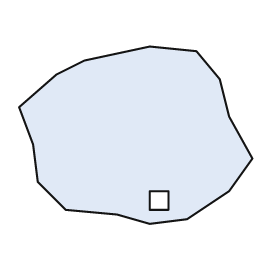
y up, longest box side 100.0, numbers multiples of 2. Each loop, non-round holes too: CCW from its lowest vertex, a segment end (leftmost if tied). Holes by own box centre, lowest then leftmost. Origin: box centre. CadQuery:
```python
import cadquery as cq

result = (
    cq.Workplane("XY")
    .moveTo(6.0, -38.0)
    .lineTo(22.0, -36.0)
    .lineTo(40.0, -24.0)
    .lineTo(50.0, -10.0)
    .lineTo(40.0, 8.0)
    .lineTo(36.0, 24.0)
    .lineTo(26.0, 36.0)
    .lineTo(6.0, 38.0)
    .lineTo(-22.0, 32.0)
    .lineTo(-34.0, 26.0)
    .lineTo(-50.0, 12.0)
    .lineTo(-44.0, -4.0)
    .lineTo(-42.0, -20.0)
    .lineTo(-30.0, -32.0)
    .lineTo(-8.0, -34.0)
    .close()
    .moveTo(6.0, -32.0)
    .lineTo(14.0, -32.0)
    .lineTo(14.0, -24.0)
    .lineTo(6.0, -24.0)
    .close()
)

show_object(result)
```